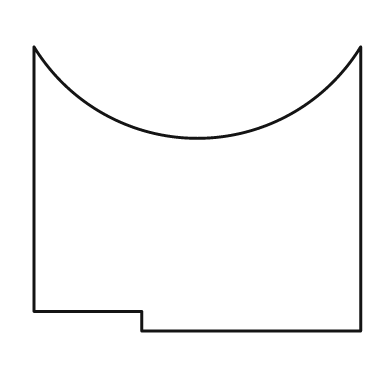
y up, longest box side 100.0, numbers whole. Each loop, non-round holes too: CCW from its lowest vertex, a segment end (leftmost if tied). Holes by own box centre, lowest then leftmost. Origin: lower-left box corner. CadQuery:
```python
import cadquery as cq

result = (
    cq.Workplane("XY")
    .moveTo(33.0, 0.0)
    .lineTo(100.0, 0.0)
    .lineTo(100.0, 87.0)
    .threePointArc((50.0, 59.0), (0.0, 87.0))
    .lineTo(0.0, 6.0)
    .lineTo(33.0, 6.0)
    .close()
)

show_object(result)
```